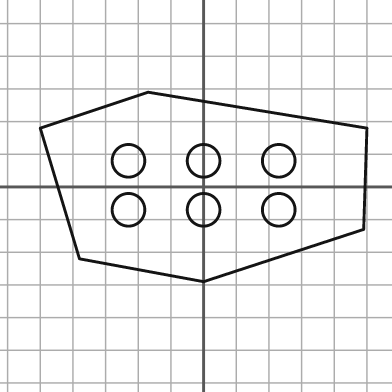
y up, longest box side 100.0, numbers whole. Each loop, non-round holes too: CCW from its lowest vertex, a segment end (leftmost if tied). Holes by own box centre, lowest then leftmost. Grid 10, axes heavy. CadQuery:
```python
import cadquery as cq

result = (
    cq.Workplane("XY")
    .moveTo(0.0, -29.0)
    .lineTo(49.0, -13.0)
    .lineTo(50.0, 18.0)
    .lineTo(-17.0, 29.0)
    .lineTo(-50.0, 18.0)
    .lineTo(-38.0, -22.0)
    .close()
    .moveTo(-23.0, -7.0)
    .circle(5.0)
    .moveTo(0.0, -7.0)
    .circle(5.0)
    .moveTo(23.0, -7.0)
    .circle(5.0)
    .moveTo(-23.0, 8.0)
    .circle(5.0)
    .moveTo(0.0, 8.0)
    .circle(5.0)
    .moveTo(23.0, 8.0)
    .circle(5.0)
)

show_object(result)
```